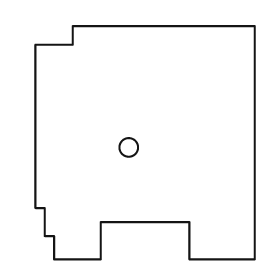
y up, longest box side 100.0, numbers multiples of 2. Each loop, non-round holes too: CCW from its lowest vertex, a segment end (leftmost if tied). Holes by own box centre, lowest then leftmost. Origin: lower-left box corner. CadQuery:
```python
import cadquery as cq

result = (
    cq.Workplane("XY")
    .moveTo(8.0, 0.0)
    .lineTo(28.0, 0.0)
    .lineTo(28.0, 16.0)
    .lineTo(66.0, 16.0)
    .lineTo(66.0, 0.0)
    .lineTo(94.0, 0.0)
    .lineTo(94.0, 100.0)
    .lineTo(16.0, 100.0)
    .lineTo(16.0, 92.0)
    .lineTo(0.0, 92.0)
    .lineTo(0.0, 22.0)
    .lineTo(4.0, 22.0)
    .lineTo(4.0, 10.0)
    .lineTo(8.0, 10.0)
    .close()
    .moveTo(40.0, 48.0)
    .circle(4.0)
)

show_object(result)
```